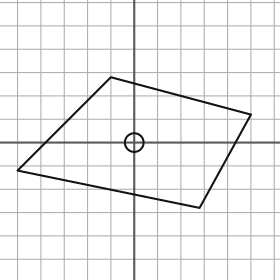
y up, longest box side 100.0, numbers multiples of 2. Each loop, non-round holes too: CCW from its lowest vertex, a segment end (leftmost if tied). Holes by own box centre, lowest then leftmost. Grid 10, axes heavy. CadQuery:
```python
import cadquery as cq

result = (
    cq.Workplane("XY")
    .moveTo(28.0, -28.0)
    .lineTo(50.0, 12.0)
    .lineTo(-10.0, 28.0)
    .lineTo(-50.0, -12.0)
    .close()
    .moveTo(0.0, 0.0)
    .circle(4.0)
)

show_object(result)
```